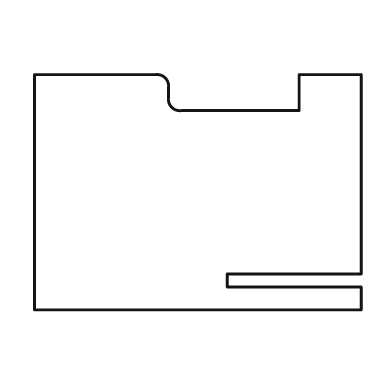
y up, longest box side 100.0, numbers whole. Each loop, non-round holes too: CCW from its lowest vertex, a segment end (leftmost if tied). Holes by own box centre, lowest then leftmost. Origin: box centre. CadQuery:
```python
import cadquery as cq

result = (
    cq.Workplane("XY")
    .moveTo(-50.0, -36.0)
    .lineTo(50.0, -36.0)
    .lineTo(50.0, -29.0)
    .lineTo(9.0, -29.0)
    .lineTo(9.0, -25.0)
    .lineTo(50.0, -25.0)
    .lineTo(50.0, 36.0)
    .lineTo(31.0, 36.0)
    .lineTo(31.0, 25.0)
    .lineTo(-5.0, 25.0)
    .threePointArc((-8.0, 26.0), (-9.0, 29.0))
    .lineTo(-9.0, 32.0)
    .threePointArc((-10.0, 35.0), (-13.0, 36.0))
    .lineTo(-50.0, 36.0)
    .close()
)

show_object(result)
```